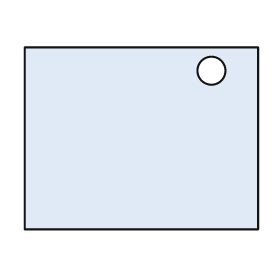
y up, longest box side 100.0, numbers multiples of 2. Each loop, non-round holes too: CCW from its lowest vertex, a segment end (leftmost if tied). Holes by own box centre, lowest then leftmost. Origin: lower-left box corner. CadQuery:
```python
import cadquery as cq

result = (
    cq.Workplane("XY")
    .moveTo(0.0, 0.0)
    .lineTo(100.0, 0.0)
    .lineTo(100.0, 78.0)
    .lineTo(0.0, 78.0)
    .close()
    .moveTo(80.0, 68.0)
    .circle(6.0)
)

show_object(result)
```